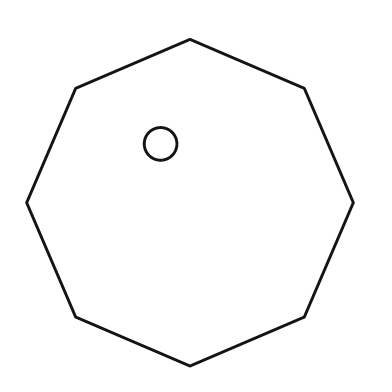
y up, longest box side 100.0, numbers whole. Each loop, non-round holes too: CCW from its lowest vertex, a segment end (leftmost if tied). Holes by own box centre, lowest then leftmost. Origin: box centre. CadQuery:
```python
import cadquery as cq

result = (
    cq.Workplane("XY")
    .moveTo(0.0, -50.0)
    .lineTo(35.0, -35.0)
    .lineTo(50.0, 0.0)
    .lineTo(35.0, 35.0)
    .lineTo(0.0, 50.0)
    .lineTo(-35.0, 35.0)
    .lineTo(-50.0, 0.0)
    .lineTo(-35.0, -35.0)
    .close()
    .moveTo(-9.0, 18.0)
    .circle(5.0)
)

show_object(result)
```